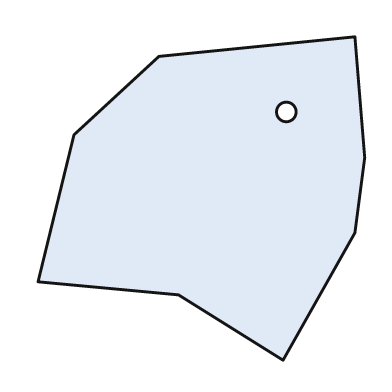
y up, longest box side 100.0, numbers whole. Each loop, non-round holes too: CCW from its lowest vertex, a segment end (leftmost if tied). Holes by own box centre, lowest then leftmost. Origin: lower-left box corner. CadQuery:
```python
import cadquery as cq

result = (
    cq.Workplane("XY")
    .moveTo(75.0, 0.0)
    .lineTo(97.0, 39.0)
    .lineTo(100.0, 62.0)
    .lineTo(97.0, 99.0)
    .lineTo(37.0, 93.0)
    .lineTo(11.0, 69.0)
    .lineTo(0.0, 24.0)
    .lineTo(43.0, 20.0)
    .close()
    .moveTo(76.0, 76.0)
    .circle(3.0)
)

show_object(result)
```